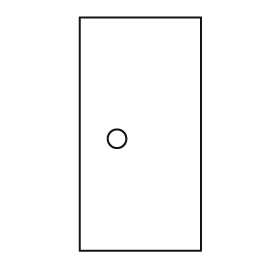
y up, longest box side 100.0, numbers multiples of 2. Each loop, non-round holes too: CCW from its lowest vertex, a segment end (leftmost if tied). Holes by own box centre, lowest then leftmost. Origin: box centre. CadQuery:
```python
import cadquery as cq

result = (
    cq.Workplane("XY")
    .moveTo(-26.0, -50.0)
    .lineTo(26.0, -50.0)
    .lineTo(26.0, 50.0)
    .lineTo(-26.0, 50.0)
    .close()
    .moveTo(-10.0, -2.0)
    .circle(4.0)
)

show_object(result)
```